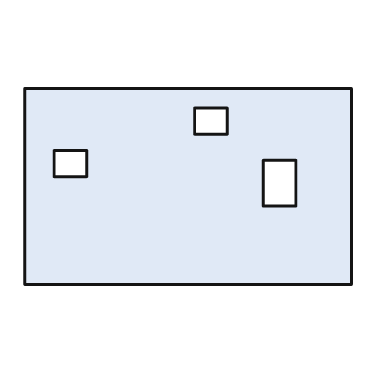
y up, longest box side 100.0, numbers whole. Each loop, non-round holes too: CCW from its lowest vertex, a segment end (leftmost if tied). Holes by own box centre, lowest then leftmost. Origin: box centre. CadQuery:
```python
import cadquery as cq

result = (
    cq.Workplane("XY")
    .moveTo(-50.0, -30.0)
    .lineTo(50.0, -30.0)
    .lineTo(50.0, 30.0)
    .lineTo(-50.0, 30.0)
    .close()
    .moveTo(23.0, -6.0)
    .lineTo(33.0, -6.0)
    .lineTo(33.0, 8.0)
    .lineTo(23.0, 8.0)
    .close()
    .moveTo(-41.0, 3.0)
    .lineTo(-31.0, 3.0)
    .lineTo(-31.0, 11.0)
    .lineTo(-41.0, 11.0)
    .close()
    .moveTo(2.0, 16.0)
    .lineTo(12.0, 16.0)
    .lineTo(12.0, 24.0)
    .lineTo(2.0, 24.0)
    .close()
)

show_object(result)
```